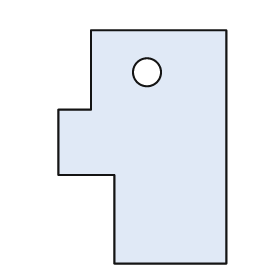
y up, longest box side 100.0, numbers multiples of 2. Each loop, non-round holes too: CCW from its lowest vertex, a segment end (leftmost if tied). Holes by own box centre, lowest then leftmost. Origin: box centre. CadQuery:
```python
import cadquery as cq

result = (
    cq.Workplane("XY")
    .moveTo(-12.0, -50.0)
    .lineTo(36.0, -50.0)
    .lineTo(36.0, 50.0)
    .lineTo(-22.0, 50.0)
    .lineTo(-22.0, 16.0)
    .lineTo(-36.0, 16.0)
    .lineTo(-36.0, -12.0)
    .lineTo(-12.0, -12.0)
    .close()
    .moveTo(2.0, 32.0)
    .circle(6.0)
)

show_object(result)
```